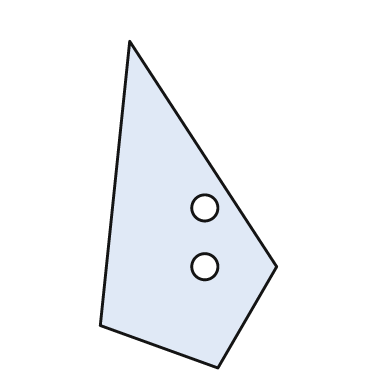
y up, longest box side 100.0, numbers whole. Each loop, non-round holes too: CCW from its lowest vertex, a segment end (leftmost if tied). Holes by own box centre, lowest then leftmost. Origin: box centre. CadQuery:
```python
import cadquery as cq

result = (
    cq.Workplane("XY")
    .moveTo(9.0, -50.0)
    .lineTo(27.0, -19.0)
    .lineTo(-18.0, 50.0)
    .lineTo(-27.0, -37.0)
    .close()
    .moveTo(5.0, -19.0)
    .circle(4.0)
    .moveTo(5.0, -1.0)
    .circle(4.0)
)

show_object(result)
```